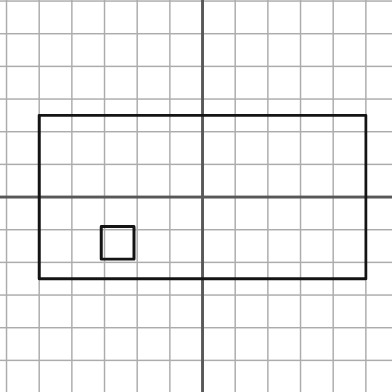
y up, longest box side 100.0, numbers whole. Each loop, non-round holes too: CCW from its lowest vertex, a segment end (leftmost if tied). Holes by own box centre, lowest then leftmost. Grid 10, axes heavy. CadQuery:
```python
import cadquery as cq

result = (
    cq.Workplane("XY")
    .moveTo(-50.0, -25.0)
    .lineTo(50.0, -25.0)
    .lineTo(50.0, 25.0)
    .lineTo(-50.0, 25.0)
    .close()
    .moveTo(-31.0, -19.0)
    .lineTo(-21.0, -19.0)
    .lineTo(-21.0, -9.0)
    .lineTo(-31.0, -9.0)
    .close()
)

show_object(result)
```